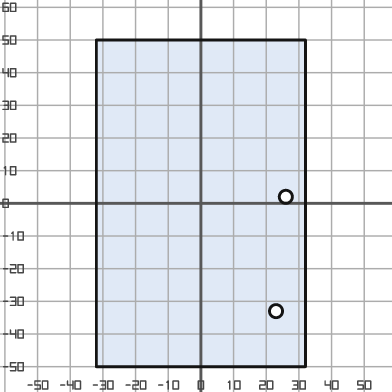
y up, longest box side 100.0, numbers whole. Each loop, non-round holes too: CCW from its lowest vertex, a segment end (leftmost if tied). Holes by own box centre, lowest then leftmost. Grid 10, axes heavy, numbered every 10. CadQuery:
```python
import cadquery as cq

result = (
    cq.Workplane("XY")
    .moveTo(-32.0, -50.0)
    .lineTo(32.0, -50.0)
    .lineTo(32.0, 50.0)
    .lineTo(-32.0, 50.0)
    .close()
    .moveTo(23.0, -33.0)
    .circle(2.0)
    .moveTo(26.0, 2.0)
    .circle(2.0)
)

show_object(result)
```